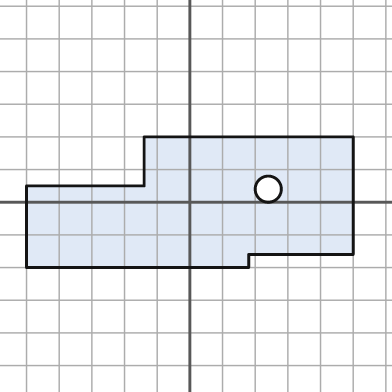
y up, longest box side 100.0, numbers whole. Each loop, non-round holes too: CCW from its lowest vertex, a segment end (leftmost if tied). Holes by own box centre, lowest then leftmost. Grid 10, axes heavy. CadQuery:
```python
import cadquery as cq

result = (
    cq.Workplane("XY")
    .moveTo(-50.0, -20.0)
    .lineTo(18.0, -20.0)
    .lineTo(18.0, -16.0)
    .lineTo(50.0, -16.0)
    .lineTo(50.0, 20.0)
    .lineTo(-14.0, 20.0)
    .lineTo(-14.0, 5.0)
    .lineTo(-50.0, 5.0)
    .close()
    .moveTo(24.0, 4.0)
    .circle(4.0)
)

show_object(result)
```